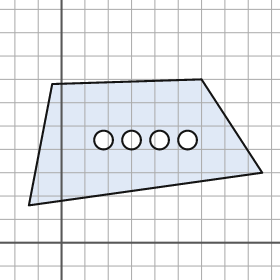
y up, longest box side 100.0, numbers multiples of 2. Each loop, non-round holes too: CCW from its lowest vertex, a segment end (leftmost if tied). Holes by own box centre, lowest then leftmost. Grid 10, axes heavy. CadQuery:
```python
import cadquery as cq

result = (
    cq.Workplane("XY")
    .moveTo(-14.0, 16.0)
    .lineTo(86.0, 30.0)
    .lineTo(60.0, 70.0)
    .lineTo(-4.0, 68.0)
    .close()
    .moveTo(18.0, 44.0)
    .circle(4.0)
    .moveTo(30.0, 44.0)
    .circle(4.0)
    .moveTo(42.0, 44.0)
    .circle(4.0)
    .moveTo(54.0, 44.0)
    .circle(4.0)
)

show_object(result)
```